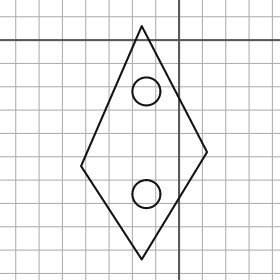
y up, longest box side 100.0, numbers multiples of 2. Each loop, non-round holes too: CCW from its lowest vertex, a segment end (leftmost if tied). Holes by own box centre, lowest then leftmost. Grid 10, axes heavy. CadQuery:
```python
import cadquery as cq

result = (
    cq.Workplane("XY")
    .moveTo(-16.0, -94.0)
    .lineTo(12.0, -48.0)
    .lineTo(-16.0, 6.0)
    .lineTo(-42.0, -54.0)
    .close()
    .moveTo(-14.0, -66.0)
    .circle(6.0)
    .moveTo(-14.0, -22.0)
    .circle(6.0)
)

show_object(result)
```